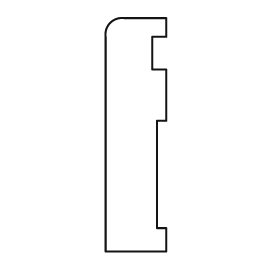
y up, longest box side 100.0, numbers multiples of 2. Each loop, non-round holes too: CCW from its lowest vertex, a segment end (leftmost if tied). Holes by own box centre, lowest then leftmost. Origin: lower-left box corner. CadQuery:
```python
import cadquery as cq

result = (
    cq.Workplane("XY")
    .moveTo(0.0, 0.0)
    .lineTo(26.0, 0.0)
    .lineTo(26.0, 10.0)
    .lineTo(22.0, 10.0)
    .lineTo(22.0, 56.0)
    .lineTo(26.0, 56.0)
    .lineTo(26.0, 78.0)
    .lineTo(20.0, 78.0)
    .lineTo(20.0, 92.0)
    .lineTo(26.0, 92.0)
    .lineTo(26.0, 100.0)
    .lineTo(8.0, 100.0)
    .threePointArc((2.0, 98.0), (0.0, 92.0))
    .close()
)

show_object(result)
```